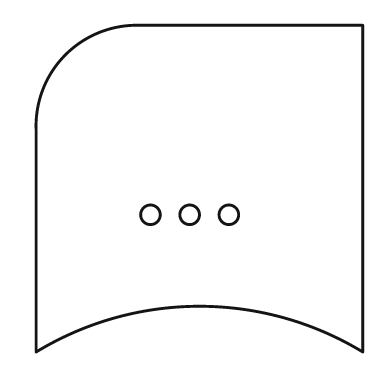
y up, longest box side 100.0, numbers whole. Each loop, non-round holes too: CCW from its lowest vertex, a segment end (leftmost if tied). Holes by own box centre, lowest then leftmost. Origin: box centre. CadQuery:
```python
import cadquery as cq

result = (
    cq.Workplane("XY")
    .moveTo(-50.0, -50.0)
    .threePointArc((0.0, -36.0), (50.0, -50.0))
    .lineTo(50.0, 50.0)
    .lineTo(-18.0, 50.0)
    .threePointArc((-41.0, 41.0), (-50.0, 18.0))
    .close()
    .moveTo(-15.0, -8.0)
    .circle(3.0)
    .moveTo(-3.0, -8.0)
    .circle(3.0)
    .moveTo(9.0, -8.0)
    .circle(3.0)
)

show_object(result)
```